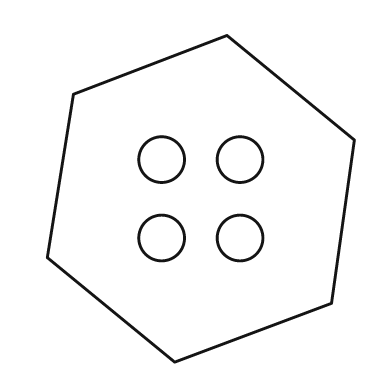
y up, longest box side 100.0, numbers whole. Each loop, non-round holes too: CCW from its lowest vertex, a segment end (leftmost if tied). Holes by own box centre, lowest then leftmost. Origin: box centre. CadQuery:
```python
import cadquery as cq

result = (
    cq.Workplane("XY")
    .moveTo(-8.0, -50.0)
    .lineTo(40.0, -32.0)
    .lineTo(47.0, 18.0)
    .lineTo(8.0, 50.0)
    .lineTo(-39.0, 32.0)
    .lineTo(-47.0, -18.0)
    .close()
    .moveTo(-12.0, -12.0)
    .circle(7.0)
    .moveTo(12.0, -12.0)
    .circle(7.0)
    .moveTo(-12.0, 12.0)
    .circle(7.0)
    .moveTo(12.0, 12.0)
    .circle(7.0)
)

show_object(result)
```